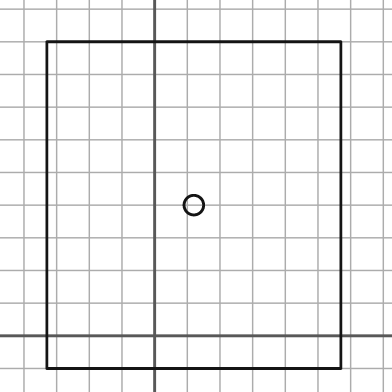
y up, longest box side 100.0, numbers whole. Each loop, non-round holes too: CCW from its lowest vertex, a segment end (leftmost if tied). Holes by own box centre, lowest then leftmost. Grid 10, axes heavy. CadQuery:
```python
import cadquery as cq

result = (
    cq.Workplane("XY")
    .moveTo(-33.0, -10.0)
    .lineTo(57.0, -10.0)
    .lineTo(57.0, 90.0)
    .lineTo(-33.0, 90.0)
    .close()
    .moveTo(12.0, 40.0)
    .circle(3.0)
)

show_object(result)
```